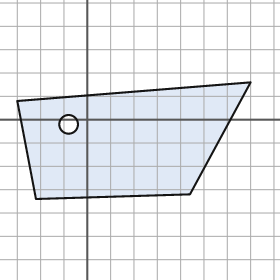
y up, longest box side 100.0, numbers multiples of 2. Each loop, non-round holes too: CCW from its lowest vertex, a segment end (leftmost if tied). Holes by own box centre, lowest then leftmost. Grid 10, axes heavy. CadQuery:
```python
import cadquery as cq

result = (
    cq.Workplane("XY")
    .moveTo(-22.0, -34.0)
    .lineTo(44.0, -32.0)
    .lineTo(70.0, 16.0)
    .lineTo(-30.0, 8.0)
    .close()
    .moveTo(-8.0, -2.0)
    .circle(4.0)
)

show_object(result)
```